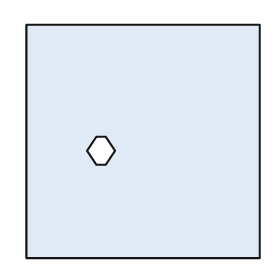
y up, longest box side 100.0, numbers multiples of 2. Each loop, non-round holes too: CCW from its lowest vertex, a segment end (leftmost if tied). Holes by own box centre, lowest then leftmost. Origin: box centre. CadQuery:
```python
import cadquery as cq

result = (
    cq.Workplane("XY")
    .moveTo(-50.0, -50.0)
    .lineTo(50.0, -50.0)
    .lineTo(50.0, 50.0)
    .lineTo(-50.0, 50.0)
    .close()
    .moveTo(-20.0, -10.0)
    .lineTo(-16.0, -10.0)
    .lineTo(-12.0, -4.0)
    .lineTo(-16.0, 2.0)
    .lineTo(-20.0, 2.0)
    .lineTo(-24.0, -4.0)
    .close()
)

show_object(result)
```